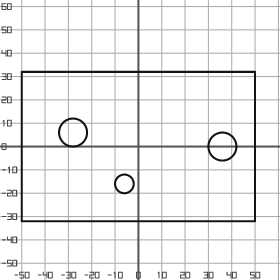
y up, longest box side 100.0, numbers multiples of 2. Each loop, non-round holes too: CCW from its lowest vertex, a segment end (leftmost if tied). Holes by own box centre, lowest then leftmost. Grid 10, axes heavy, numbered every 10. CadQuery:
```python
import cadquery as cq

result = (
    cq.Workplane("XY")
    .moveTo(-50.0, -32.0)
    .lineTo(50.0, -32.0)
    .lineTo(50.0, 32.0)
    .lineTo(-50.0, 32.0)
    .close()
    .moveTo(-6.0, -16.0)
    .circle(4.0)
    .moveTo(36.0, 0.0)
    .circle(6.0)
    .moveTo(-28.0, 6.0)
    .circle(6.0)
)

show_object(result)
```